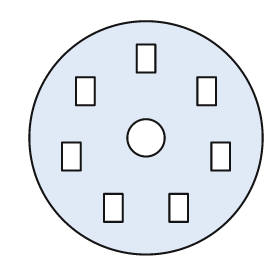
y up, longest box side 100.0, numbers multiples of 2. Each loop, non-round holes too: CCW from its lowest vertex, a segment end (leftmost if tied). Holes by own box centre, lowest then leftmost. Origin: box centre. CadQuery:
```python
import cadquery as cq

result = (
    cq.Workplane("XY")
    .moveTo(0.0, 0.0)
    .circle(50.0)
    .moveTo(-18.0, -36.0)
    .lineTo(-10.0, -36.0)
    .lineTo(-10.0, -24.0)
    .lineTo(-18.0, -24.0)
    .close()
    .moveTo(10.0, -36.0)
    .lineTo(18.0, -36.0)
    .lineTo(18.0, -24.0)
    .lineTo(10.0, -24.0)
    .close()
    .moveTo(-36.0, -14.0)
    .lineTo(-28.0, -14.0)
    .lineTo(-28.0, -2.0)
    .lineTo(-36.0, -2.0)
    .close()
    .moveTo(28.0, -14.0)
    .lineTo(36.0, -14.0)
    .lineTo(36.0, -2.0)
    .lineTo(28.0, -2.0)
    .close()
    .moveTo(0.0, 0.0)
    .circle(8.0)
    .moveTo(-30.0, 14.0)
    .lineTo(-22.0, 14.0)
    .lineTo(-22.0, 26.0)
    .lineTo(-30.0, 26.0)
    .close()
    .moveTo(22.0, 14.0)
    .lineTo(30.0, 14.0)
    .lineTo(30.0, 26.0)
    .lineTo(22.0, 26.0)
    .close()
    .moveTo(-4.0, 28.0)
    .lineTo(4.0, 28.0)
    .lineTo(4.0, 40.0)
    .lineTo(-4.0, 40.0)
    .close()
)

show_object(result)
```